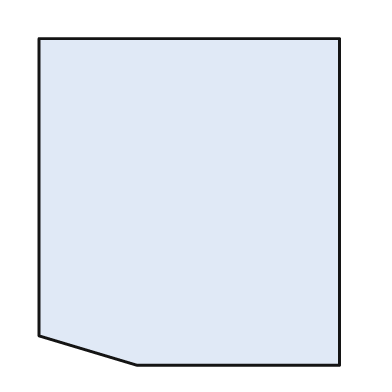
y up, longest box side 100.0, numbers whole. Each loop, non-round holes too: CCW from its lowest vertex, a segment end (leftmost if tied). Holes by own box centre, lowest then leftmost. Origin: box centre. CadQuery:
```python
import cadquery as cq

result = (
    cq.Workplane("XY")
    .moveTo(-16.0, -50.0)
    .lineTo(46.0, -50.0)
    .lineTo(46.0, 50.0)
    .lineTo(-46.0, 50.0)
    .lineTo(-46.0, -41.0)
    .close()
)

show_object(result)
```